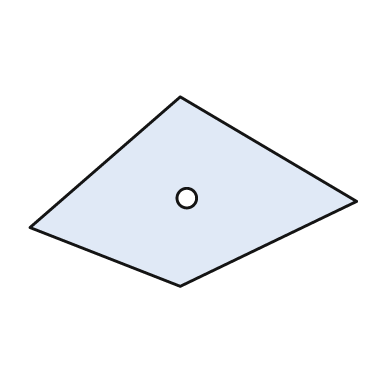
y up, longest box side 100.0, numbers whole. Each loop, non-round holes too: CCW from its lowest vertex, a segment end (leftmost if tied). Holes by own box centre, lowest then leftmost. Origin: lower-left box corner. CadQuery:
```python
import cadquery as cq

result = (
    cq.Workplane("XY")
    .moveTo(46.0, 0.0)
    .lineTo(100.0, 26.0)
    .lineTo(46.0, 58.0)
    .lineTo(0.0, 18.0)
    .close()
    .moveTo(48.0, 27.0)
    .circle(3.0)
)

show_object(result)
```